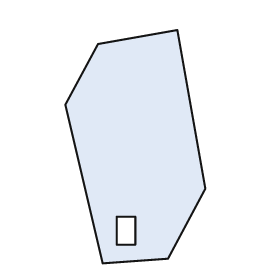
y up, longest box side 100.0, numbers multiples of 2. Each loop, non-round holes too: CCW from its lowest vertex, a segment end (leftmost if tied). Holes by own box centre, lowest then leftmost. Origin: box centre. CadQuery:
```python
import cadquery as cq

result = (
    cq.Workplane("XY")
    .moveTo(-14.0, -50.0)
    .lineTo(14.0, -48.0)
    .lineTo(30.0, -18.0)
    .lineTo(18.0, 50.0)
    .lineTo(-16.0, 44.0)
    .lineTo(-30.0, 18.0)
    .close()
    .moveTo(-8.0, -42.0)
    .lineTo(0.0, -42.0)
    .lineTo(0.0, -30.0)
    .lineTo(-8.0, -30.0)
    .close()
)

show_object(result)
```